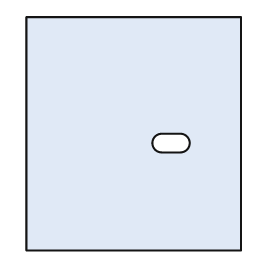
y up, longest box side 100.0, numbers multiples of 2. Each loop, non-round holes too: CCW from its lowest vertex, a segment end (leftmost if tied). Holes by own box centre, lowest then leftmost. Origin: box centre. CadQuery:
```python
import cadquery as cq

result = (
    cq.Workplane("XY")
    .moveTo(-46.0, -50.0)
    .lineTo(46.0, -50.0)
    .lineTo(46.0, 50.0)
    .lineTo(-46.0, 50.0)
    .close()
    .moveTo(12.0, -8.0)
    .lineTo(20.0, -8.0)
    .threePointArc((24.0, -4.0), (20.0, 0.0))
    .lineTo(12.0, 0.0)
    .threePointArc((8.0, -4.0), (12.0, -8.0))
    .close()
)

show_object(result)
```